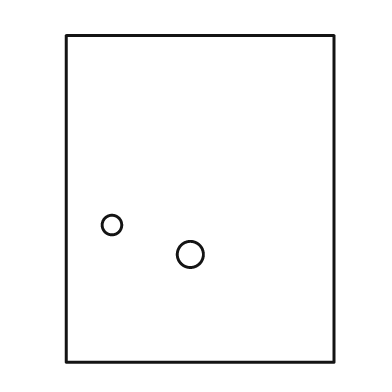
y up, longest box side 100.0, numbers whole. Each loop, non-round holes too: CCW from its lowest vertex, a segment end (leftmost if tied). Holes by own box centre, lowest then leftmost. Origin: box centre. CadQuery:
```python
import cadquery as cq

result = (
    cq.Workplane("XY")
    .moveTo(-41.0, -50.0)
    .lineTo(41.0, -50.0)
    .lineTo(41.0, 50.0)
    .lineTo(-41.0, 50.0)
    .close()
    .moveTo(-3.0, -17.0)
    .circle(4.0)
    .moveTo(-27.0, -8.0)
    .circle(3.0)
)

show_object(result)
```